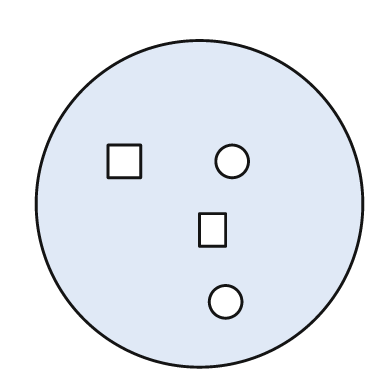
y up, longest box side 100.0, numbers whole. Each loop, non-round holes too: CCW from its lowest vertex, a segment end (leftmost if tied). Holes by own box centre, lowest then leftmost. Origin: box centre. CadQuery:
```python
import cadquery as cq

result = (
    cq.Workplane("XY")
    .moveTo(0.0, 0.0)
    .circle(50.0)
    .moveTo(8.0, -30.0)
    .circle(5.0)
    .moveTo(0.0, -13.0)
    .lineTo(8.0, -13.0)
    .lineTo(8.0, -3.0)
    .lineTo(0.0, -3.0)
    .close()
    .moveTo(-28.0, 8.0)
    .lineTo(-18.0, 8.0)
    .lineTo(-18.0, 18.0)
    .lineTo(-28.0, 18.0)
    .close()
    .moveTo(10.0, 13.0)
    .circle(5.0)
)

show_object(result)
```